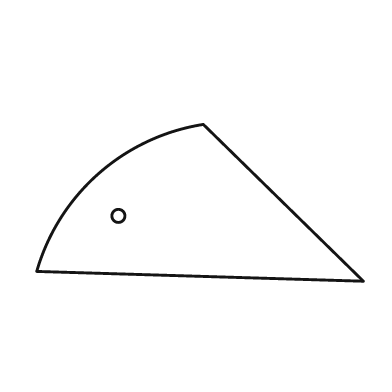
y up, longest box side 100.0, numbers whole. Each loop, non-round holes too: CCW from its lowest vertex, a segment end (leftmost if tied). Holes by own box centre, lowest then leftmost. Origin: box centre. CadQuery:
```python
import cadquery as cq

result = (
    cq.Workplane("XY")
    .moveTo(50.0, -24.0)
    .lineTo(1.0, 24.0)
    .threePointArc((-31.0, 9.0), (-50.0, -21.0))
    .close()
    .moveTo(-25.0, -4.0)
    .circle(2.0)
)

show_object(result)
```